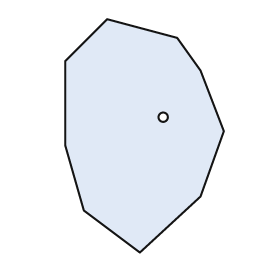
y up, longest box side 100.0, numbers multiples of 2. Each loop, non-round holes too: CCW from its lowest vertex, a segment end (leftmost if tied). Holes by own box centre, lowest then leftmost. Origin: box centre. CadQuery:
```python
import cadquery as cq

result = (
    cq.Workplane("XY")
    .moveTo(-2.0, -50.0)
    .lineTo(24.0, -26.0)
    .lineTo(34.0, 2.0)
    .lineTo(24.0, 28.0)
    .lineTo(14.0, 42.0)
    .lineTo(-16.0, 50.0)
    .lineTo(-34.0, 32.0)
    .lineTo(-34.0, -4.0)
    .lineTo(-26.0, -32.0)
    .close()
    .moveTo(8.0, 8.0)
    .circle(2.0)
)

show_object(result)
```